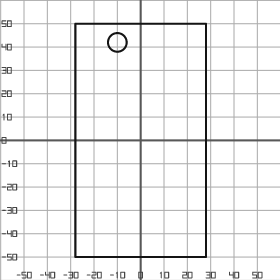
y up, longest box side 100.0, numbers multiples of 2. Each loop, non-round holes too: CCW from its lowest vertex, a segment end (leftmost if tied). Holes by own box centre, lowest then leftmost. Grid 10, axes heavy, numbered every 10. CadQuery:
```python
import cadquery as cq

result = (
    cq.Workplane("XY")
    .moveTo(-28.0, -50.0)
    .lineTo(28.0, -50.0)
    .lineTo(28.0, 50.0)
    .lineTo(-28.0, 50.0)
    .close()
    .moveTo(-10.0, 42.0)
    .circle(4.0)
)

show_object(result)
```